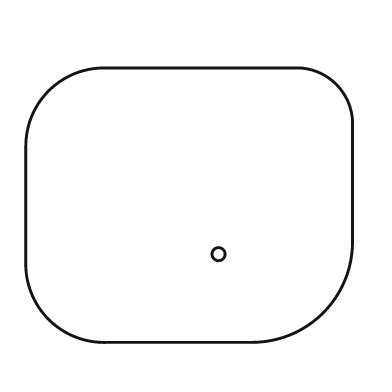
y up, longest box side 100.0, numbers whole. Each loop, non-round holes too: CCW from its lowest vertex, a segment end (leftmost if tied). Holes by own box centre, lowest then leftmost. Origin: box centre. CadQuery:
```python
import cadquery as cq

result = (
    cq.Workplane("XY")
    .moveTo(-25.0, -42.0)
    .lineTo(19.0, -42.0)
    .threePointArc((41.0, -33.0), (50.0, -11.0))
    .lineTo(50.0, 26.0)
    .threePointArc((45.0, 37.0), (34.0, 42.0))
    .lineTo(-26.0, 42.0)
    .threePointArc((-43.0, 35.0), (-50.0, 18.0))
    .lineTo(-50.0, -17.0)
    .threePointArc((-43.0, -35.0), (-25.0, -42.0))
    .close()
    .moveTo(9.0, -15.0)
    .circle(2.0)
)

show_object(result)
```